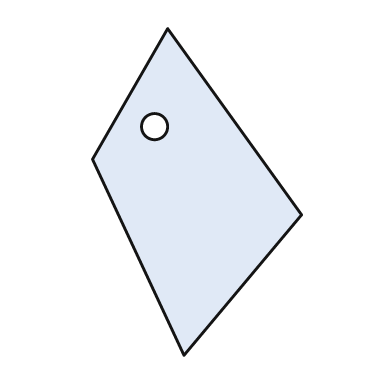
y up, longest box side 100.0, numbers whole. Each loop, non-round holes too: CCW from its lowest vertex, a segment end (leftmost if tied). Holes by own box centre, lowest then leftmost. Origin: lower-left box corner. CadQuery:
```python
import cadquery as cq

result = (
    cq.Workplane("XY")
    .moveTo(28.0, 0.0)
    .lineTo(64.0, 43.0)
    .lineTo(23.0, 100.0)
    .lineTo(0.0, 60.0)
    .close()
    .moveTo(19.0, 70.0)
    .circle(4.0)
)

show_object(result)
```